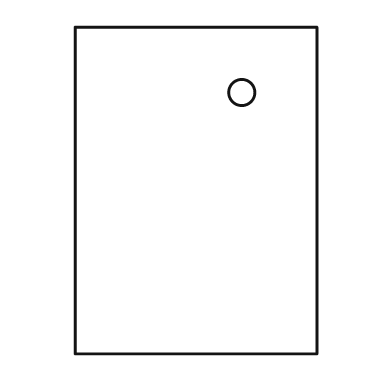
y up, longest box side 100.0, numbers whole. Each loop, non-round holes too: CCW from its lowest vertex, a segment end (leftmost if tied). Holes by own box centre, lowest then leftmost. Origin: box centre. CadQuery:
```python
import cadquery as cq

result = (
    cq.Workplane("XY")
    .moveTo(-37.0, -50.0)
    .lineTo(37.0, -50.0)
    .lineTo(37.0, 50.0)
    .lineTo(-37.0, 50.0)
    .close()
    .moveTo(14.0, 30.0)
    .circle(4.0)
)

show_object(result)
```